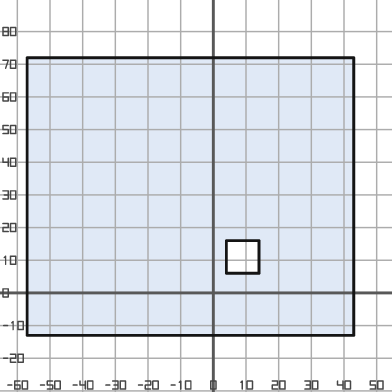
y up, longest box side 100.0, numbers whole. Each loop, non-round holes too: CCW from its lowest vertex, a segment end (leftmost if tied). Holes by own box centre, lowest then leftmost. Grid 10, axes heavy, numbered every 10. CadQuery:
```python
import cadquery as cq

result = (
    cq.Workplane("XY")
    .moveTo(-57.0, -13.0)
    .lineTo(43.0, -13.0)
    .lineTo(43.0, 72.0)
    .lineTo(-57.0, 72.0)
    .close()
    .moveTo(4.0, 6.0)
    .lineTo(14.0, 6.0)
    .lineTo(14.0, 16.0)
    .lineTo(4.0, 16.0)
    .close()
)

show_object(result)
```